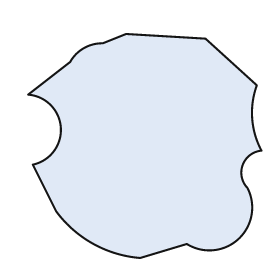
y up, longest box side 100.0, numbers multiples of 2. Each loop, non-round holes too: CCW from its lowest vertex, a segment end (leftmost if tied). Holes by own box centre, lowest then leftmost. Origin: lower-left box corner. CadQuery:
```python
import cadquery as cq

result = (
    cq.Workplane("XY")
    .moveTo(48.0, 0.0)
    .lineTo(68.0, 6.0)
    .threePointArc((90.0, 8.0), (94.0, 30.0))
    .threePointArc((92.0, 40.0), (100.0, 46.0))
    .threePointArc((96.0, 60.0), (98.0, 74.0))
    .lineTo(76.0, 94.0)
    .lineTo(42.0, 96.0)
    .lineTo(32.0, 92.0)
    .threePointArc((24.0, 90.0), (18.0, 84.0))
    .lineTo(0.0, 70.0)
    .threePointArc((14.0, 56.0), (2.0, 40.0))
    .lineTo(12.0, 20.0)
    .threePointArc((28.0, 6.0), (48.0, 0.0))
    .close()
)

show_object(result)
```